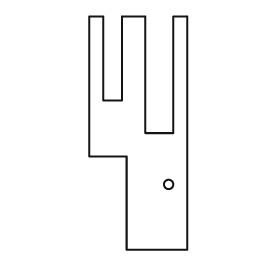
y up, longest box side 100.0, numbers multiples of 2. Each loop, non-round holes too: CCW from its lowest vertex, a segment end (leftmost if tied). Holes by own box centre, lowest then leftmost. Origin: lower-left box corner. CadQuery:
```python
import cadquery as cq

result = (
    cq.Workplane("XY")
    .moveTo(16.0, 0.0)
    .lineTo(42.0, 0.0)
    .lineTo(42.0, 100.0)
    .lineTo(36.0, 100.0)
    .lineTo(36.0, 50.0)
    .lineTo(24.0, 50.0)
    .lineTo(24.0, 100.0)
    .lineTo(14.0, 100.0)
    .lineTo(14.0, 64.0)
    .lineTo(6.0, 64.0)
    .lineTo(6.0, 100.0)
    .lineTo(0.0, 100.0)
    .lineTo(0.0, 40.0)
    .lineTo(16.0, 40.0)
    .close()
    .moveTo(34.0, 28.0)
    .circle(2.0)
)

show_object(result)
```